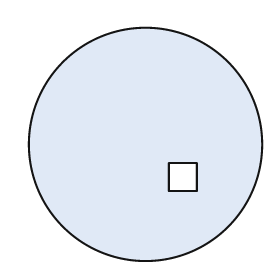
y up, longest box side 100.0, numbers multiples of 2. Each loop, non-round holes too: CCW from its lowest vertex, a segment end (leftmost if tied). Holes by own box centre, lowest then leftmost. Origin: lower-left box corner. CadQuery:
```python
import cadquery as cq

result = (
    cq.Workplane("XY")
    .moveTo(50.0, 50.0)
    .circle(50.0)
    .moveTo(60.0, 30.0)
    .lineTo(72.0, 30.0)
    .lineTo(72.0, 42.0)
    .lineTo(60.0, 42.0)
    .close()
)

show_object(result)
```